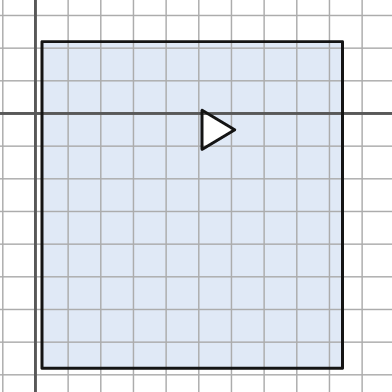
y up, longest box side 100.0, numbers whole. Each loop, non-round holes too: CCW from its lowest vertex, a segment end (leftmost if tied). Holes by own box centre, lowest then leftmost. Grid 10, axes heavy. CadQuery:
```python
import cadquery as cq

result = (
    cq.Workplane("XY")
    .moveTo(2.0, -78.0)
    .lineTo(94.0, -78.0)
    .lineTo(94.0, 22.0)
    .lineTo(2.0, 22.0)
    .close()
    .moveTo(51.0, -11.0)
    .lineTo(61.0, -5.0)
    .lineTo(51.0, 1.0)
    .close()
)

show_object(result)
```